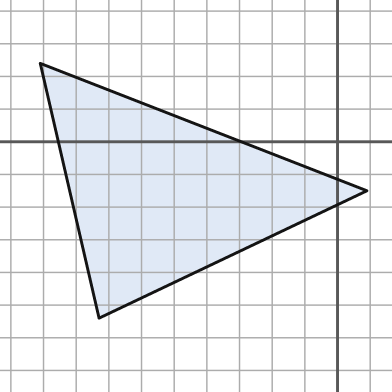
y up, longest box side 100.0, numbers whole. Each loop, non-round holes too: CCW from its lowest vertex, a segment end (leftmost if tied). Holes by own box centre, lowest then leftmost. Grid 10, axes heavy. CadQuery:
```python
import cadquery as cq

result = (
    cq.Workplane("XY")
    .moveTo(-73.0, -54.0)
    .lineTo(9.0, -15.0)
    .lineTo(-91.0, 24.0)
    .close()
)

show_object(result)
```